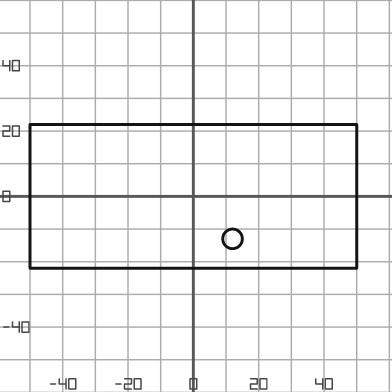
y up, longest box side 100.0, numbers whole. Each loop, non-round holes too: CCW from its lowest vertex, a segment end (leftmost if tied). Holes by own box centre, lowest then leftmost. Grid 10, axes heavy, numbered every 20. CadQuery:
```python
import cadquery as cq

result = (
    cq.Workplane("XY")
    .moveTo(-50.0, -22.0)
    .lineTo(50.0, -22.0)
    .lineTo(50.0, 22.0)
    .lineTo(-50.0, 22.0)
    .close()
    .moveTo(12.0, -13.0)
    .circle(3.0)
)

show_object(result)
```